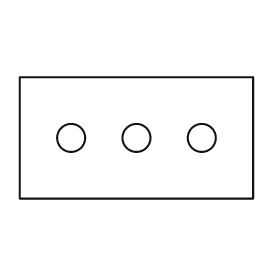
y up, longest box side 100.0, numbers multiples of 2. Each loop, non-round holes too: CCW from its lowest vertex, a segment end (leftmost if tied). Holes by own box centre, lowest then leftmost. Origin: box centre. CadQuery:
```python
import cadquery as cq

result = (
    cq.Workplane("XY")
    .moveTo(-50.0, -26.0)
    .lineTo(50.0, -26.0)
    .lineTo(50.0, 26.0)
    .lineTo(-50.0, 26.0)
    .close()
    .moveTo(-28.0, 0.0)
    .circle(6.0)
    .moveTo(0.0, 0.0)
    .circle(6.0)
    .moveTo(28.0, 0.0)
    .circle(6.0)
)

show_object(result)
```